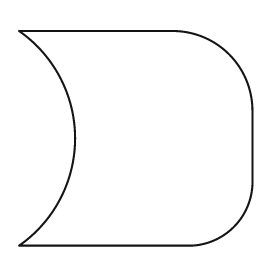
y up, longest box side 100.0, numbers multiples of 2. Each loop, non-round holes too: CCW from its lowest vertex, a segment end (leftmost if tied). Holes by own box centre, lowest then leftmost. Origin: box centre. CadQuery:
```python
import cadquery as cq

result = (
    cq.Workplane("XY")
    .moveTo(-50.0, -46.0)
    .lineTo(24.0, -46.0)
    .threePointArc((42.0, -38.0), (50.0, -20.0))
    .lineTo(50.0, 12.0)
    .threePointArc((40.0, 36.0), (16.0, 46.0))
    .lineTo(-50.0, 46.0)
    .threePointArc((-26.0, 0.0), (-50.0, -46.0))
    .close()
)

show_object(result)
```